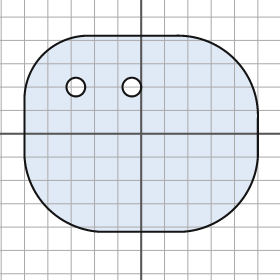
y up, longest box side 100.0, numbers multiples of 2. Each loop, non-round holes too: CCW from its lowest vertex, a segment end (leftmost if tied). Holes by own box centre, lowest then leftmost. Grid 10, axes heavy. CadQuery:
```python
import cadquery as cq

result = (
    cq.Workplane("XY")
    .moveTo(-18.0, -42.0)
    .lineTo(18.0, -42.0)
    .threePointArc((40.0, -32.0), (50.0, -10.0))
    .lineTo(50.0, 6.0)
    .threePointArc((40.0, 32.0), (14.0, 42.0))
    .lineTo(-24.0, 42.0)
    .threePointArc((-42.0, 34.0), (-50.0, 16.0))
    .lineTo(-50.0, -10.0)
    .threePointArc((-40.0, -32.0), (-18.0, -42.0))
    .close()
    .moveTo(-28.0, 20.0)
    .circle(4.0)
    .moveTo(-4.0, 20.0)
    .circle(4.0)
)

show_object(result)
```